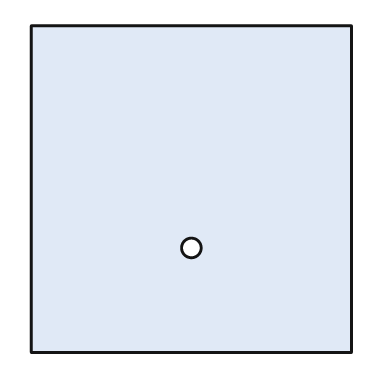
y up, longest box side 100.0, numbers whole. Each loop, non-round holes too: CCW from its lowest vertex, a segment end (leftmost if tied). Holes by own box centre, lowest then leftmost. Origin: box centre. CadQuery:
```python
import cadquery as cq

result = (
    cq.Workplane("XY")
    .moveTo(-49.0, -50.0)
    .lineTo(49.0, -50.0)
    .lineTo(49.0, 50.0)
    .lineTo(-49.0, 50.0)
    .close()
    .moveTo(0.0, -18.0)
    .circle(3.0)
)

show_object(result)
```